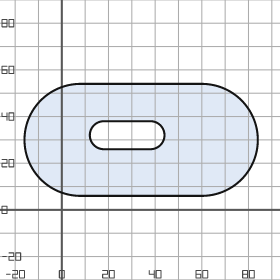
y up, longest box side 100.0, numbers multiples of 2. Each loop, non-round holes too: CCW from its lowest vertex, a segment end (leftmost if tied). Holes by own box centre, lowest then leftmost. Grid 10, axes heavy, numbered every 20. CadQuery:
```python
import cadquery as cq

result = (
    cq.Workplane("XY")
    .moveTo(8.0, 6.0)
    .lineTo(60.0, 6.0)
    .threePointArc((84.0, 30.0), (60.0, 54.0))
    .lineTo(8.0, 54.0)
    .threePointArc((-16.0, 30.0), (8.0, 6.0))
    .close()
    .moveTo(18.0, 26.0)
    .lineTo(38.0, 26.0)
    .threePointArc((44.0, 32.0), (38.0, 38.0))
    .lineTo(18.0, 38.0)
    .threePointArc((12.0, 32.0), (18.0, 26.0))
    .close()
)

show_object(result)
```